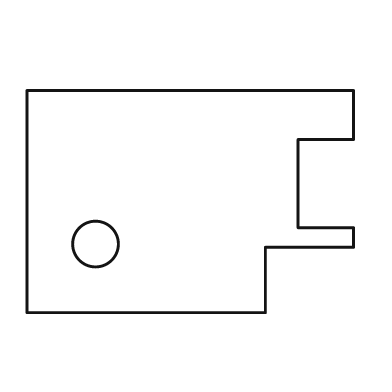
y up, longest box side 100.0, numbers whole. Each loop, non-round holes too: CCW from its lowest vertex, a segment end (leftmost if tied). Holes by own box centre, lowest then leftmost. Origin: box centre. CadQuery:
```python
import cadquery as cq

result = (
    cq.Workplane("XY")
    .moveTo(-50.0, -34.0)
    .lineTo(23.0, -34.0)
    .lineTo(23.0, -14.0)
    .lineTo(50.0, -14.0)
    .lineTo(50.0, -8.0)
    .lineTo(33.0, -8.0)
    .lineTo(33.0, 19.0)
    .lineTo(50.0, 19.0)
    .lineTo(50.0, 34.0)
    .lineTo(-50.0, 34.0)
    .close()
    .moveTo(-29.0, -13.0)
    .circle(7.0)
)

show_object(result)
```